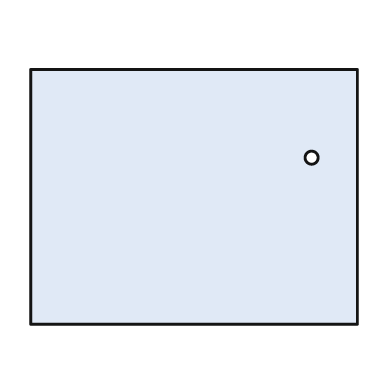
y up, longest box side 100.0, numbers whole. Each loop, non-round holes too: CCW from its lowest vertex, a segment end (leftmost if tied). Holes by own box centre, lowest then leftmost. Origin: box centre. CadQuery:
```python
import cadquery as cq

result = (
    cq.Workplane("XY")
    .moveTo(-50.0, -39.0)
    .lineTo(50.0, -39.0)
    .lineTo(50.0, 39.0)
    .lineTo(-50.0, 39.0)
    .close()
    .moveTo(36.0, 12.0)
    .circle(2.0)
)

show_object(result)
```